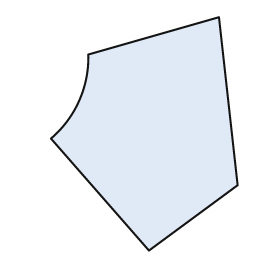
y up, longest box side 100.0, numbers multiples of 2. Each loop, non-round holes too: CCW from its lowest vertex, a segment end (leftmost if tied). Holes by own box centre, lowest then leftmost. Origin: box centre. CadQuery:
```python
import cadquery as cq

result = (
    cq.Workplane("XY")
    .moveTo(2.0, -50.0)
    .lineTo(40.0, -22.0)
    .lineTo(32.0, 50.0)
    .lineTo(-24.0, 34.0)
    .threePointArc((-28.0, 14.0), (-40.0, -2.0))
    .close()
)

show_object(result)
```